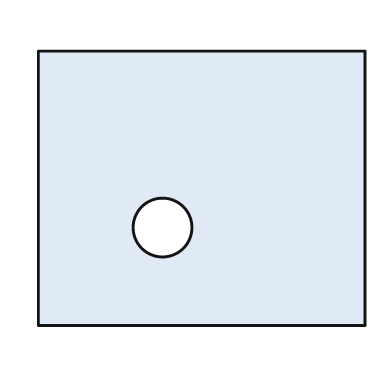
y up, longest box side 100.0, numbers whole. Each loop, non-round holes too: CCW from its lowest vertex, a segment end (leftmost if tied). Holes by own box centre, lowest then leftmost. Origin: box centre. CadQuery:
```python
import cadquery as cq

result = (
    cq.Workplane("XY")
    .moveTo(-50.0, -42.0)
    .lineTo(50.0, -42.0)
    .lineTo(50.0, 42.0)
    .lineTo(-50.0, 42.0)
    .close()
    .moveTo(-12.0, -12.0)
    .circle(9.0)
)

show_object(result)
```